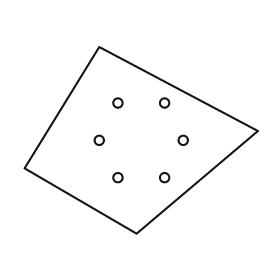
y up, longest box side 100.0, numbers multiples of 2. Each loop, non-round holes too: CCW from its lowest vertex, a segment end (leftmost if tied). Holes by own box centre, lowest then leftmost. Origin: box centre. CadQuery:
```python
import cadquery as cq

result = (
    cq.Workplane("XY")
    .moveTo(-2.0, -40.0)
    .lineTo(50.0, 4.0)
    .lineTo(-18.0, 40.0)
    .lineTo(-50.0, -12.0)
    .close()
    .moveTo(-10.0, -16.0)
    .circle(2.0)
    .moveTo(10.0, -16.0)
    .circle(2.0)
    .moveTo(-18.0, 0.0)
    .circle(2.0)
    .moveTo(18.0, 0.0)
    .circle(2.0)
    .moveTo(-10.0, 16.0)
    .circle(2.0)
    .moveTo(10.0, 16.0)
    .circle(2.0)
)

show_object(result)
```